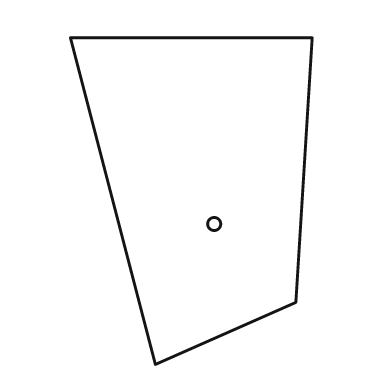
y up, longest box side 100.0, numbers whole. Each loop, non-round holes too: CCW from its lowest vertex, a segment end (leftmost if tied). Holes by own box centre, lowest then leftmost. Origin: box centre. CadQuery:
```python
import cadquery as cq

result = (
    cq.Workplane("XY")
    .moveTo(-11.0, -50.0)
    .lineTo(32.0, -31.0)
    .lineTo(37.0, 50.0)
    .lineTo(-37.0, 50.0)
    .close()
    .moveTo(7.0, -7.0)
    .circle(2.0)
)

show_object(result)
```